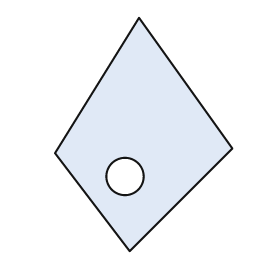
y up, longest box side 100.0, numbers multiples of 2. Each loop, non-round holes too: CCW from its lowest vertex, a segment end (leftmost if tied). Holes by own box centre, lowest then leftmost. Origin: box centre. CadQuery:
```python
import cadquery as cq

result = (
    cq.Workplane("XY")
    .moveTo(-6.0, -50.0)
    .lineTo(38.0, -6.0)
    .lineTo(-2.0, 50.0)
    .lineTo(-38.0, -8.0)
    .close()
    .moveTo(-8.0, -18.0)
    .circle(8.0)
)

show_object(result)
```